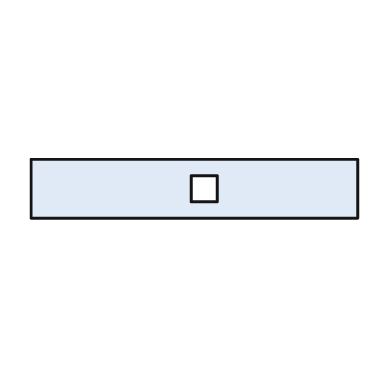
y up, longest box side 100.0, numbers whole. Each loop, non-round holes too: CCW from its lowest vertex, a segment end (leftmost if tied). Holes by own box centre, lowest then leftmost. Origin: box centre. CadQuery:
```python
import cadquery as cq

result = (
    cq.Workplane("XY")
    .moveTo(-50.0, -9.0)
    .lineTo(50.0, -9.0)
    .lineTo(50.0, 9.0)
    .lineTo(-50.0, 9.0)
    .close()
    .moveTo(-1.0, -4.0)
    .lineTo(7.0, -4.0)
    .lineTo(7.0, 4.0)
    .lineTo(-1.0, 4.0)
    .close()
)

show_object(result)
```